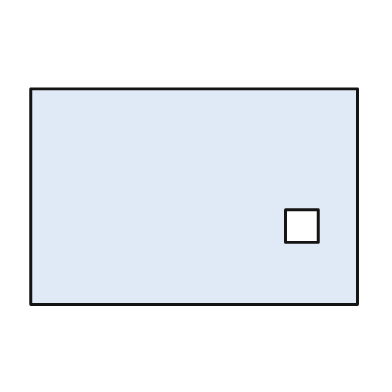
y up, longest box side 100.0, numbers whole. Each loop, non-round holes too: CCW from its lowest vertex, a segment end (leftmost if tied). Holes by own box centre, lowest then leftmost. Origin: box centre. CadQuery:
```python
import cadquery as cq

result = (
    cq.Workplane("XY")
    .moveTo(-50.0, -33.0)
    .lineTo(50.0, -33.0)
    .lineTo(50.0, 33.0)
    .lineTo(-50.0, 33.0)
    .close()
    .moveTo(28.0, -14.0)
    .lineTo(38.0, -14.0)
    .lineTo(38.0, -4.0)
    .lineTo(28.0, -4.0)
    .close()
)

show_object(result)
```